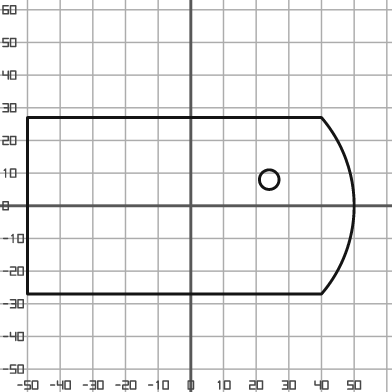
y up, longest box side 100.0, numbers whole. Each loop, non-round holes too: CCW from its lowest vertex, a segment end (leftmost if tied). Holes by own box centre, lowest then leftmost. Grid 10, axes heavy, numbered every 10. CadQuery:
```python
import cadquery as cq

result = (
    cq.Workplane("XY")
    .moveTo(-50.0, -27.0)
    .lineTo(40.0, -27.0)
    .threePointArc((50.0, 0.0), (40.0, 27.0))
    .lineTo(-50.0, 27.0)
    .close()
    .moveTo(24.0, 8.0)
    .circle(3.0)
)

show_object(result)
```